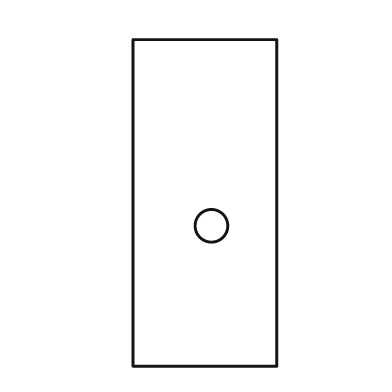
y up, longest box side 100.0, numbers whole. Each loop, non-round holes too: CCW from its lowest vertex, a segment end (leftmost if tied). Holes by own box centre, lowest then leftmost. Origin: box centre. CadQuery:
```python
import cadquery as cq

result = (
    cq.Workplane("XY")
    .moveTo(-22.0, -50.0)
    .lineTo(22.0, -50.0)
    .lineTo(22.0, 50.0)
    .lineTo(-22.0, 50.0)
    .close()
    .moveTo(2.0, -7.0)
    .circle(5.0)
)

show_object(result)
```